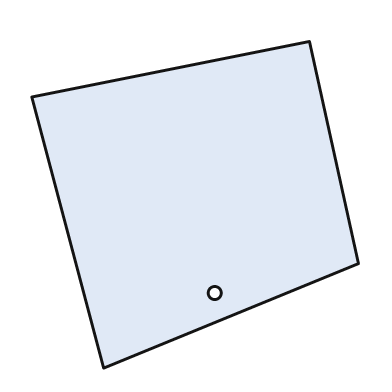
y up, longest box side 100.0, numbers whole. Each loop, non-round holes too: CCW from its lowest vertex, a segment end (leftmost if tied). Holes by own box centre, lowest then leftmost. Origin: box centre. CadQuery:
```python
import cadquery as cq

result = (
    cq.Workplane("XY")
    .moveTo(-28.0, -50.0)
    .lineTo(50.0, -18.0)
    .lineTo(35.0, 50.0)
    .lineTo(-50.0, 33.0)
    .close()
    .moveTo(6.0, -27.0)
    .circle(2.0)
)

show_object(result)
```